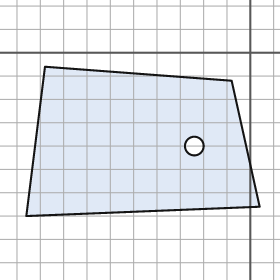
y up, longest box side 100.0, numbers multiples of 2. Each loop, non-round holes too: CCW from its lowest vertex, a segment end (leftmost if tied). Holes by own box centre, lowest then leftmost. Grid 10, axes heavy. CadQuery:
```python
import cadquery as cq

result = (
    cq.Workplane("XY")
    .moveTo(-96.0, -70.0)
    .lineTo(4.0, -66.0)
    .lineTo(-8.0, -12.0)
    .lineTo(-88.0, -6.0)
    .close()
    .moveTo(-24.0, -40.0)
    .circle(4.0)
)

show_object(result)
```